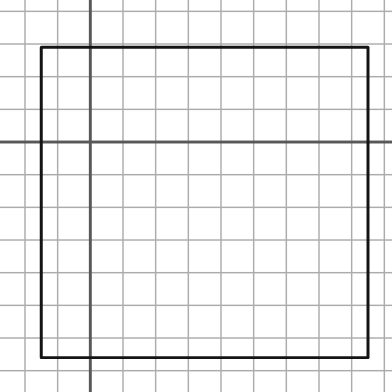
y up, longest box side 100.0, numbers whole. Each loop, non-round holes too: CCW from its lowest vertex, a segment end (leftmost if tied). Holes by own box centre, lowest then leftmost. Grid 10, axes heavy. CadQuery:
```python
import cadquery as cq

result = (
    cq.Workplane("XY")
    .moveTo(-15.0, -66.0)
    .lineTo(85.0, -66.0)
    .lineTo(85.0, 29.0)
    .lineTo(-15.0, 29.0)
    .close()
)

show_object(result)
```